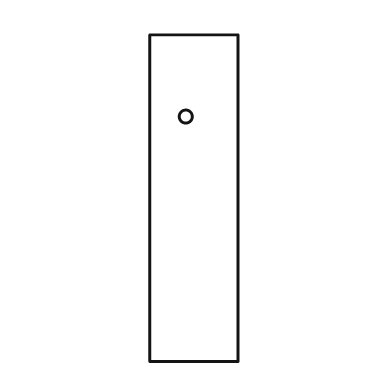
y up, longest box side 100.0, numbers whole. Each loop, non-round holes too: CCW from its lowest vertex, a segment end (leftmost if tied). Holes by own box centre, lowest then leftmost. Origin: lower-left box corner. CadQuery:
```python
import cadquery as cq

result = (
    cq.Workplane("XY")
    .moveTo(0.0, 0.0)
    .lineTo(27.0, 0.0)
    .lineTo(27.0, 100.0)
    .lineTo(0.0, 100.0)
    .close()
    .moveTo(11.0, 75.0)
    .circle(2.0)
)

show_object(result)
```